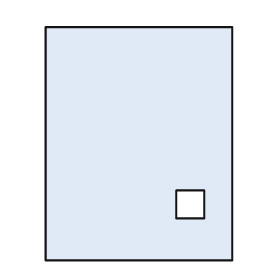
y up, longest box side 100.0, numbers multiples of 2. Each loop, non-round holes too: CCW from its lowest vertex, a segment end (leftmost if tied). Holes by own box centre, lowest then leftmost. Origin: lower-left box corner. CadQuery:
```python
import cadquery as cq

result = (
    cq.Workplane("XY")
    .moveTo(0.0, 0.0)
    .lineTo(80.0, 0.0)
    .lineTo(80.0, 100.0)
    .lineTo(0.0, 100.0)
    .close()
    .moveTo(56.0, 18.0)
    .lineTo(68.0, 18.0)
    .lineTo(68.0, 30.0)
    .lineTo(56.0, 30.0)
    .close()
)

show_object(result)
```